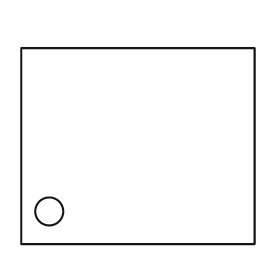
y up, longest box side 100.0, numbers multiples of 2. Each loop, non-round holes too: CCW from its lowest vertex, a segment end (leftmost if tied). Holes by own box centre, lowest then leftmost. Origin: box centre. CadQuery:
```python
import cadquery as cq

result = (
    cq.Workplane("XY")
    .moveTo(-50.0, -42.0)
    .lineTo(50.0, -42.0)
    .lineTo(50.0, 42.0)
    .lineTo(-50.0, 42.0)
    .close()
    .moveTo(-38.0, -28.0)
    .circle(6.0)
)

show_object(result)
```